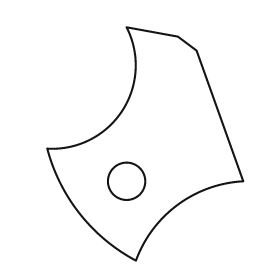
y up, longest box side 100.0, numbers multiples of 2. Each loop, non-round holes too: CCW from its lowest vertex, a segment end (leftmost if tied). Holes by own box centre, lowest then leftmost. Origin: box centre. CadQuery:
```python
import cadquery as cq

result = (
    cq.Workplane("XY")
    .moveTo(-4.0, -50.0)
    .threePointArc((14.0, -26.0), (42.0, -16.0))
    .lineTo(22.0, 40.0)
    .lineTo(14.0, 46.0)
    .lineTo(-8.0, 50.0)
    .threePointArc((-10.0, 14.0), (-42.0, -2.0))
    .threePointArc((-28.0, -30.0), (-4.0, -50.0))
    .close()
    .moveTo(-8.0, -16.0)
    .circle(8.0)
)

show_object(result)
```